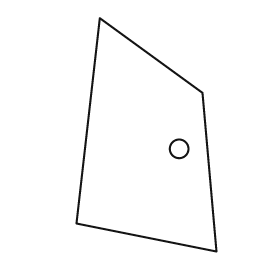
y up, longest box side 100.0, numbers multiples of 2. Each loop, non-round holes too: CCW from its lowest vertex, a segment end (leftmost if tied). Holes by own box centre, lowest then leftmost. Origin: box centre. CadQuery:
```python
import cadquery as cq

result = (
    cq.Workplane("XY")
    .moveTo(30.0, -50.0)
    .lineTo(24.0, 18.0)
    .lineTo(-20.0, 50.0)
    .lineTo(-30.0, -38.0)
    .close()
    .moveTo(14.0, -6.0)
    .circle(4.0)
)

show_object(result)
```